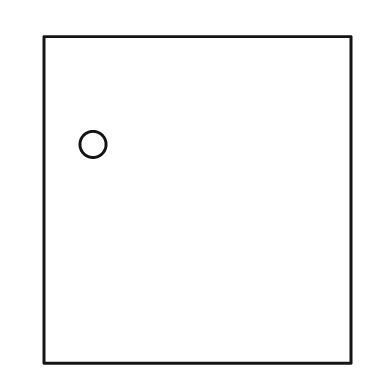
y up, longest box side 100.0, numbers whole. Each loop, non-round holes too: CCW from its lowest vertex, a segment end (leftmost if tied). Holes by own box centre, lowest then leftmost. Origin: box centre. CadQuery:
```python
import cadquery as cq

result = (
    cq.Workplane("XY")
    .moveTo(-47.0, -50.0)
    .lineTo(47.0, -50.0)
    .lineTo(47.0, 50.0)
    .lineTo(-47.0, 50.0)
    .close()
    .moveTo(-32.0, 17.0)
    .circle(4.0)
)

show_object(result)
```